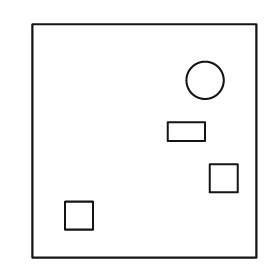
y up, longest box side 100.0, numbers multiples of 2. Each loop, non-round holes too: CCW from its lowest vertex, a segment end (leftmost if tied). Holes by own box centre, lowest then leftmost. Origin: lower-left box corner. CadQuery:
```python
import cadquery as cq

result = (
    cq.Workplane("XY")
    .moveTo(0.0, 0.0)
    .lineTo(96.0, 0.0)
    .lineTo(96.0, 100.0)
    .lineTo(0.0, 100.0)
    .close()
    .moveTo(14.0, 12.0)
    .lineTo(26.0, 12.0)
    .lineTo(26.0, 24.0)
    .lineTo(14.0, 24.0)
    .close()
    .moveTo(76.0, 28.0)
    .lineTo(88.0, 28.0)
    .lineTo(88.0, 40.0)
    .lineTo(76.0, 40.0)
    .close()
    .moveTo(58.0, 50.0)
    .lineTo(74.0, 50.0)
    .lineTo(74.0, 58.0)
    .lineTo(58.0, 58.0)
    .close()
    .moveTo(74.0, 76.0)
    .circle(8.0)
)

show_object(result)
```